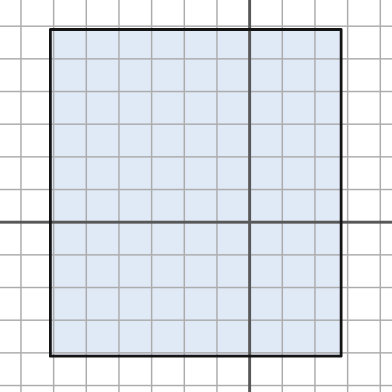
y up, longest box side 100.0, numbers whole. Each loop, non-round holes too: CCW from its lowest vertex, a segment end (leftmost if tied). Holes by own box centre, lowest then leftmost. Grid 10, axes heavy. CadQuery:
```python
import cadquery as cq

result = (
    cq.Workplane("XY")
    .moveTo(-61.0, -41.0)
    .lineTo(28.0, -41.0)
    .lineTo(28.0, 59.0)
    .lineTo(-61.0, 59.0)
    .close()
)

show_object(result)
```